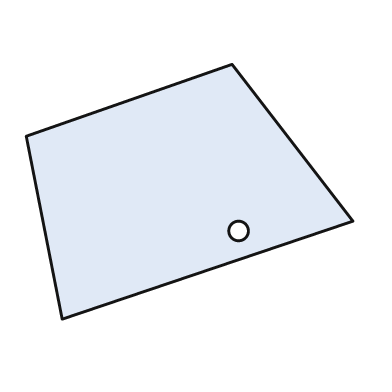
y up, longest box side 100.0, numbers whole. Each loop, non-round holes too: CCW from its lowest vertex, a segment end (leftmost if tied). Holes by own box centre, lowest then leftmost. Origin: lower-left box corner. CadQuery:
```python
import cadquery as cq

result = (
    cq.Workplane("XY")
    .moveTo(11.0, 0.0)
    .lineTo(100.0, 30.0)
    .lineTo(63.0, 78.0)
    .lineTo(0.0, 56.0)
    .close()
    .moveTo(65.0, 27.0)
    .circle(3.0)
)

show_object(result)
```